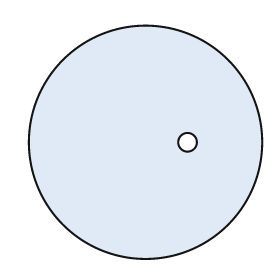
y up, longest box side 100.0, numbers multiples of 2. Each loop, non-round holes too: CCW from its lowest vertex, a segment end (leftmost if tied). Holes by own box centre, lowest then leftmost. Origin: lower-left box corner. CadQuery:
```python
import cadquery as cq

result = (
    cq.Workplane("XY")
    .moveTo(50.0, 50.0)
    .circle(50.0)
    .moveTo(68.0, 50.0)
    .circle(4.0)
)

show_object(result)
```